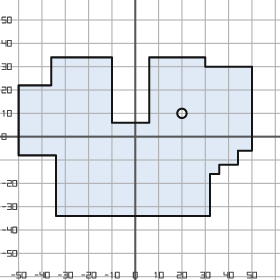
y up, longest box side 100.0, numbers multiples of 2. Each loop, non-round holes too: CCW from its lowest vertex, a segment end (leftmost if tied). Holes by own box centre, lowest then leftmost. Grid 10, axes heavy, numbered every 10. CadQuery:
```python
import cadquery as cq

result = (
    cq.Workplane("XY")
    .moveTo(-34.0, -34.0)
    .lineTo(32.0, -34.0)
    .lineTo(32.0, -16.0)
    .lineTo(36.0, -16.0)
    .lineTo(36.0, -12.0)
    .lineTo(44.0, -12.0)
    .lineTo(44.0, -6.0)
    .lineTo(50.0, -6.0)
    .lineTo(50.0, 30.0)
    .lineTo(30.0, 30.0)
    .lineTo(30.0, 34.0)
    .lineTo(6.0, 34.0)
    .lineTo(6.0, 6.0)
    .lineTo(-10.0, 6.0)
    .lineTo(-10.0, 34.0)
    .lineTo(-36.0, 34.0)
    .lineTo(-36.0, 22.0)
    .lineTo(-50.0, 22.0)
    .lineTo(-50.0, -8.0)
    .lineTo(-34.0, -8.0)
    .close()
    .moveTo(20.0, 10.0)
    .circle(2.0)
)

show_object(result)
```